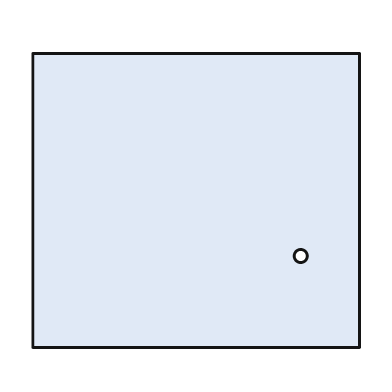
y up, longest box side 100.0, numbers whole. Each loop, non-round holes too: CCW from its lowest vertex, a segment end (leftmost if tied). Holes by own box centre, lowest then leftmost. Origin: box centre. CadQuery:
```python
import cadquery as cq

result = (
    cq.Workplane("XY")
    .moveTo(-50.0, -45.0)
    .lineTo(50.0, -45.0)
    .lineTo(50.0, 45.0)
    .lineTo(-50.0, 45.0)
    .close()
    .moveTo(32.0, -17.0)
    .circle(2.0)
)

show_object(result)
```